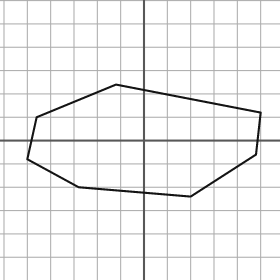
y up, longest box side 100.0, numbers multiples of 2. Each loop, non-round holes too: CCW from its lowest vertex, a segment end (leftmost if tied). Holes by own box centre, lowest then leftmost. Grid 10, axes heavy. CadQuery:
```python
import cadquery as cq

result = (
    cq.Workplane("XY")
    .moveTo(20.0, -24.0)
    .lineTo(48.0, -6.0)
    .lineTo(50.0, 12.0)
    .lineTo(-12.0, 24.0)
    .lineTo(-46.0, 10.0)
    .lineTo(-50.0, -8.0)
    .lineTo(-28.0, -20.0)
    .close()
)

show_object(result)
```